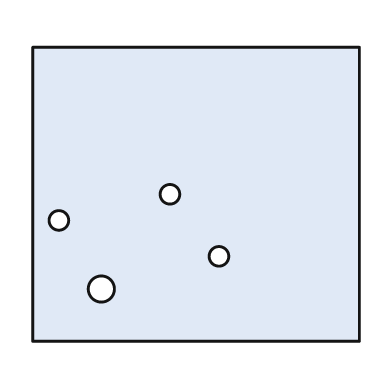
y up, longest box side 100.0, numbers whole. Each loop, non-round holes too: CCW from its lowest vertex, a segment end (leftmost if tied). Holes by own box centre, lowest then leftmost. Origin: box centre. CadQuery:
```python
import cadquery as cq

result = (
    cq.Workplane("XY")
    .moveTo(-50.0, -45.0)
    .lineTo(50.0, -45.0)
    .lineTo(50.0, 45.0)
    .lineTo(-50.0, 45.0)
    .close()
    .moveTo(-29.0, -29.0)
    .circle(4.0)
    .moveTo(7.0, -19.0)
    .circle(3.0)
    .moveTo(-42.0, -8.0)
    .circle(3.0)
    .moveTo(-8.0, 0.0)
    .circle(3.0)
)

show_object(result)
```